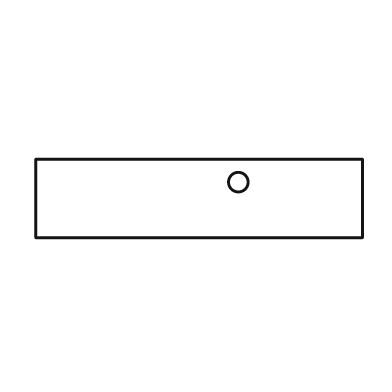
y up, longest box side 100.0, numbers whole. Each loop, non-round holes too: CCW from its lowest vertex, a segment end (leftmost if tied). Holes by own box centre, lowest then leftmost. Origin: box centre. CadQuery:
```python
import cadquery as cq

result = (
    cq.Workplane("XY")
    .moveTo(-50.0, -12.0)
    .lineTo(50.0, -12.0)
    .lineTo(50.0, 12.0)
    .lineTo(-50.0, 12.0)
    .close()
    .moveTo(12.0, 5.0)
    .circle(3.0)
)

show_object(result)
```